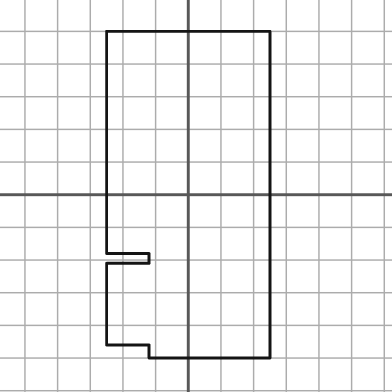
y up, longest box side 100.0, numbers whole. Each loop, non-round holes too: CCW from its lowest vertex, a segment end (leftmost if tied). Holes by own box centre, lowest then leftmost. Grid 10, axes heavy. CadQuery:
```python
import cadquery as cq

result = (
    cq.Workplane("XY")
    .moveTo(-12.0, -50.0)
    .lineTo(25.0, -50.0)
    .lineTo(25.0, 50.0)
    .lineTo(-25.0, 50.0)
    .lineTo(-25.0, -18.0)
    .lineTo(-12.0, -18.0)
    .lineTo(-12.0, -21.0)
    .lineTo(-25.0, -21.0)
    .lineTo(-25.0, -46.0)
    .lineTo(-12.0, -46.0)
    .close()
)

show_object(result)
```